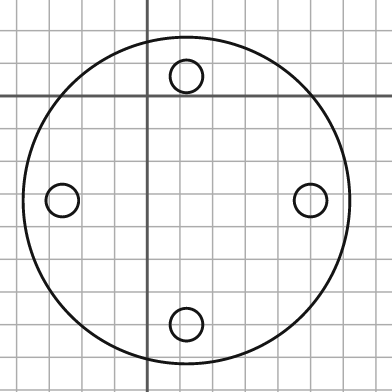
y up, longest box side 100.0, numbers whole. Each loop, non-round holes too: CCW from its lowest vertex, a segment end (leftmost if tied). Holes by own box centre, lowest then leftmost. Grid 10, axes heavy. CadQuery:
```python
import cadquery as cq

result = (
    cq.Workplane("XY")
    .moveTo(12.0, -32.0)
    .circle(50.0)
    .moveTo(12.0, -70.0)
    .circle(5.0)
    .moveTo(-26.0, -32.0)
    .circle(5.0)
    .moveTo(50.0, -32.0)
    .circle(5.0)
    .moveTo(12.0, 6.0)
    .circle(5.0)
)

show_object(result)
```